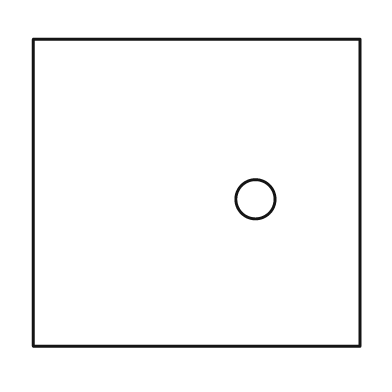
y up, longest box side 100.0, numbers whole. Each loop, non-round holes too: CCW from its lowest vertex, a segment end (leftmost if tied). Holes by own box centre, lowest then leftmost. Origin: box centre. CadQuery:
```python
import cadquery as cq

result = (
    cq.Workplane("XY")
    .moveTo(-50.0, -47.0)
    .lineTo(50.0, -47.0)
    .lineTo(50.0, 47.0)
    .lineTo(-50.0, 47.0)
    .close()
    .moveTo(18.0, -2.0)
    .circle(6.0)
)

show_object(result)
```